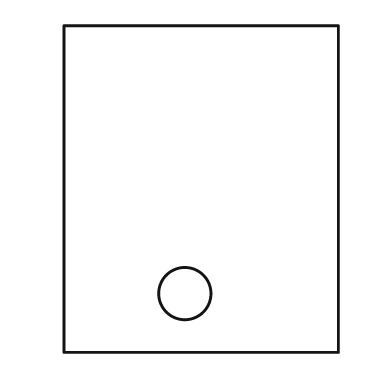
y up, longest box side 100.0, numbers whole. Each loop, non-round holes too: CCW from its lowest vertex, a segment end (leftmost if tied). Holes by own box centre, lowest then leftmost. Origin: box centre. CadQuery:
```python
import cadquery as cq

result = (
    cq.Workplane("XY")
    .moveTo(-42.0, -50.0)
    .lineTo(42.0, -50.0)
    .lineTo(42.0, 50.0)
    .lineTo(-42.0, 50.0)
    .close()
    .moveTo(-5.0, -32.0)
    .circle(8.0)
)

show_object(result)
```